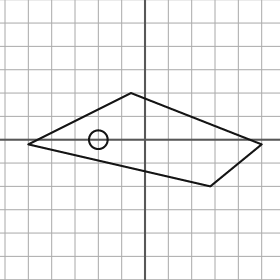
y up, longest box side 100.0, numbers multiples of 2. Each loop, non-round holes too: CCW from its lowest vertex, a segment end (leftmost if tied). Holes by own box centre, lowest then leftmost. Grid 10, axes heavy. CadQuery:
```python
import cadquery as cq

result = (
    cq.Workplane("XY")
    .moveTo(28.0, -20.0)
    .lineTo(50.0, -2.0)
    .lineTo(-6.0, 20.0)
    .lineTo(-50.0, -2.0)
    .close()
    .moveTo(-20.0, 0.0)
    .circle(4.0)
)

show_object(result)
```